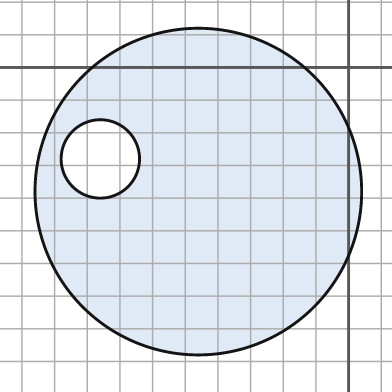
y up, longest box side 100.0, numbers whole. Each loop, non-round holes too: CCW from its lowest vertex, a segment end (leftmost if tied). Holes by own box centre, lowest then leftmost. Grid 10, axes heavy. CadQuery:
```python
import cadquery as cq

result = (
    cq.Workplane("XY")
    .moveTo(-46.0, -38.0)
    .circle(50.0)
    .moveTo(-76.0, -28.0)
    .circle(12.0)
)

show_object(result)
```